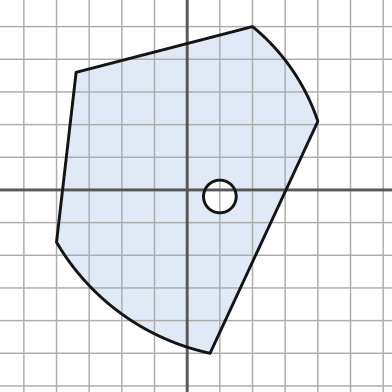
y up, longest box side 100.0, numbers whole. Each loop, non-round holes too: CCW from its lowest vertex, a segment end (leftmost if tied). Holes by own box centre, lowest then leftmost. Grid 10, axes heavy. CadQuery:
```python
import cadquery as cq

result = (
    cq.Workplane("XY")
    .moveTo(7.0, -50.0)
    .lineTo(40.0, 21.0)
    .threePointArc((32.0, 37.0), (20.0, 50.0))
    .lineTo(-34.0, 36.0)
    .lineTo(-40.0, -16.0)
    .threePointArc((-20.0, -38.0), (7.0, -50.0))
    .close()
    .moveTo(10.0, -2.0)
    .circle(5.0)
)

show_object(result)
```